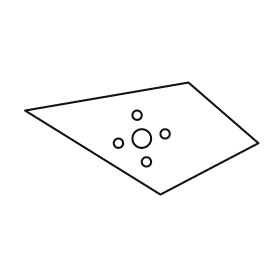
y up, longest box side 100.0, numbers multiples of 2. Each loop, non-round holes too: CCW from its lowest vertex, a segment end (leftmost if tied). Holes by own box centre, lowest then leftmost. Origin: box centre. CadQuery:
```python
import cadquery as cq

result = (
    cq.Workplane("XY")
    .moveTo(8.0, -24.0)
    .lineTo(50.0, -2.0)
    .lineTo(20.0, 24.0)
    .lineTo(-50.0, 12.0)
    .close()
    .moveTo(2.0, -10.0)
    .circle(2.0)
    .moveTo(-10.0, -2.0)
    .circle(2.0)
    .moveTo(0.0, 0.0)
    .circle(4.0)
    .moveTo(10.0, 2.0)
    .circle(2.0)
    .moveTo(-2.0, 10.0)
    .circle(2.0)
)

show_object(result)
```